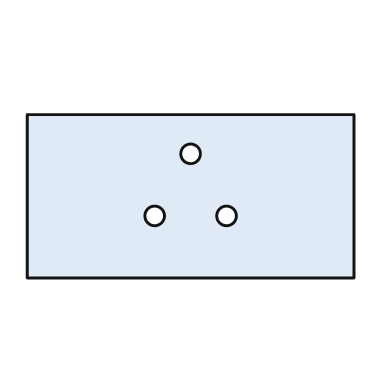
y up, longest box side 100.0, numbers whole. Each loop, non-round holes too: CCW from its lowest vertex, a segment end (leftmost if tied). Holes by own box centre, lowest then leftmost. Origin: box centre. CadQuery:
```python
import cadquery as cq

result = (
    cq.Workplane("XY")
    .moveTo(-50.0, -25.0)
    .lineTo(50.0, -25.0)
    .lineTo(50.0, 25.0)
    .lineTo(-50.0, 25.0)
    .close()
    .moveTo(-11.0, -6.0)
    .circle(3.0)
    .moveTo(11.0, -6.0)
    .circle(3.0)
    .moveTo(0.0, 13.0)
    .circle(3.0)
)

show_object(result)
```